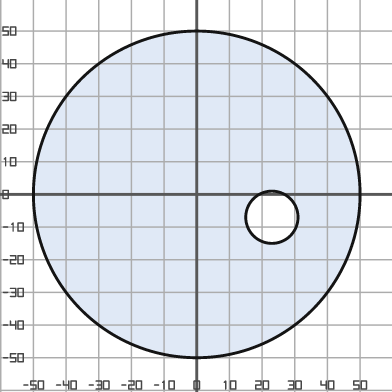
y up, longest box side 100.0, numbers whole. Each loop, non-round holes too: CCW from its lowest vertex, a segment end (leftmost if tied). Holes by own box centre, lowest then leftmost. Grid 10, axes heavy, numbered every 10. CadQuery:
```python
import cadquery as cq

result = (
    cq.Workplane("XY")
    .moveTo(0.0, 0.0)
    .circle(50.0)
    .moveTo(23.0, -7.0)
    .circle(8.0)
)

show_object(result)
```